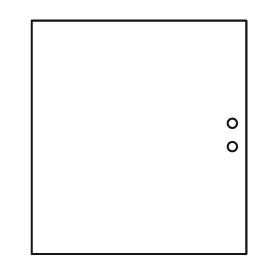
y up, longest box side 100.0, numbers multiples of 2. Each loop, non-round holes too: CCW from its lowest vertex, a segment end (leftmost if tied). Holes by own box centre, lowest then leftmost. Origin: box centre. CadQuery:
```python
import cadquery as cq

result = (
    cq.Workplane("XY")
    .moveTo(-46.0, -50.0)
    .lineTo(46.0, -50.0)
    .lineTo(46.0, 50.0)
    .lineTo(-46.0, 50.0)
    .close()
    .moveTo(40.0, -4.0)
    .circle(2.0)
    .moveTo(40.0, 6.0)
    .circle(2.0)
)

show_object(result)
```